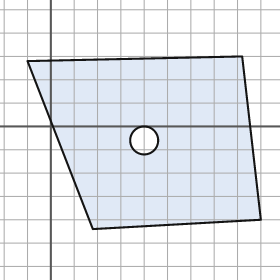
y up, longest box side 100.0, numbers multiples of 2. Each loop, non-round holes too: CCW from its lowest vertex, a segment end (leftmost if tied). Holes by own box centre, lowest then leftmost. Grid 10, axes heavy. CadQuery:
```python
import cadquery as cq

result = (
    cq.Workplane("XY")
    .moveTo(18.0, -44.0)
    .lineTo(90.0, -40.0)
    .lineTo(82.0, 30.0)
    .lineTo(-10.0, 28.0)
    .close()
    .moveTo(40.0, -6.0)
    .circle(6.0)
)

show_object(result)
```